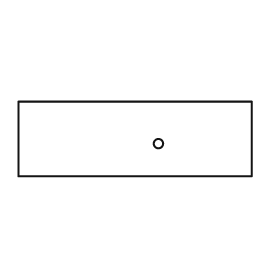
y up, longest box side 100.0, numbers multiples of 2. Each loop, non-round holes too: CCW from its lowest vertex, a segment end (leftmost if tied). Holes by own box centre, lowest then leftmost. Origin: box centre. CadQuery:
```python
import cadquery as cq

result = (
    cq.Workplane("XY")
    .moveTo(-50.0, -16.0)
    .lineTo(50.0, -16.0)
    .lineTo(50.0, 16.0)
    .lineTo(-50.0, 16.0)
    .close()
    .moveTo(10.0, -2.0)
    .circle(2.0)
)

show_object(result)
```